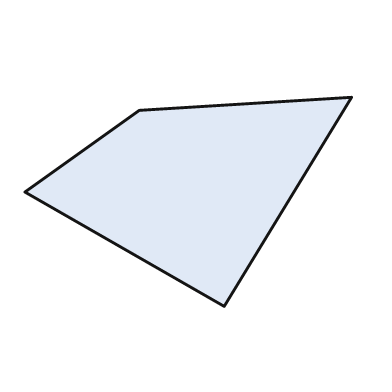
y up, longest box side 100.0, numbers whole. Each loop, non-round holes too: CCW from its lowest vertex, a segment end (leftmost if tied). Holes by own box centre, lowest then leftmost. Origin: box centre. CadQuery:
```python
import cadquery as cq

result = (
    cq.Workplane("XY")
    .moveTo(11.0, -32.0)
    .lineTo(50.0, 32.0)
    .lineTo(-15.0, 28.0)
    .lineTo(-50.0, 3.0)
    .close()
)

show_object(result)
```